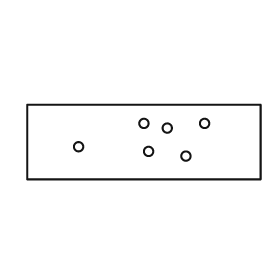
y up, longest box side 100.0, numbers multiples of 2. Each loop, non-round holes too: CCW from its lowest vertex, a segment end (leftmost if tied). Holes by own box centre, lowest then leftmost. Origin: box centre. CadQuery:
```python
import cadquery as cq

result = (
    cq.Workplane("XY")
    .moveTo(-50.0, -16.0)
    .lineTo(50.0, -16.0)
    .lineTo(50.0, 16.0)
    .lineTo(-50.0, 16.0)
    .close()
    .moveTo(18.0, -6.0)
    .circle(2.0)
    .moveTo(2.0, -4.0)
    .circle(2.0)
    .moveTo(-28.0, -2.0)
    .circle(2.0)
    .moveTo(10.0, 6.0)
    .circle(2.0)
    .moveTo(0.0, 8.0)
    .circle(2.0)
    .moveTo(26.0, 8.0)
    .circle(2.0)
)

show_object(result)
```